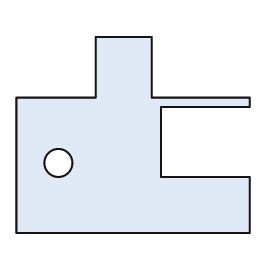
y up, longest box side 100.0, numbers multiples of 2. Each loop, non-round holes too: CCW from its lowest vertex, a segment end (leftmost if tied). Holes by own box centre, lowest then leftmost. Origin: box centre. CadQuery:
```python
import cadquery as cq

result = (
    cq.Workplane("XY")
    .moveTo(-50.0, -42.0)
    .lineTo(50.0, -42.0)
    .lineTo(50.0, -18.0)
    .lineTo(12.0, -18.0)
    .lineTo(12.0, 12.0)
    .lineTo(50.0, 12.0)
    .lineTo(50.0, 16.0)
    .lineTo(8.0, 16.0)
    .lineTo(8.0, 42.0)
    .lineTo(-16.0, 42.0)
    .lineTo(-16.0, 16.0)
    .lineTo(-50.0, 16.0)
    .close()
    .moveTo(-32.0, -12.0)
    .circle(6.0)
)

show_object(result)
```